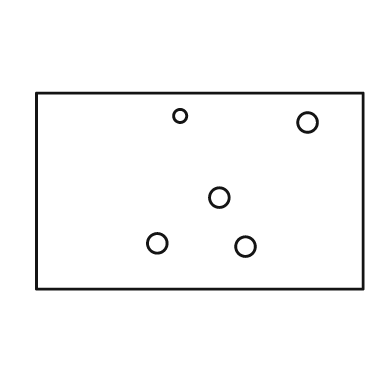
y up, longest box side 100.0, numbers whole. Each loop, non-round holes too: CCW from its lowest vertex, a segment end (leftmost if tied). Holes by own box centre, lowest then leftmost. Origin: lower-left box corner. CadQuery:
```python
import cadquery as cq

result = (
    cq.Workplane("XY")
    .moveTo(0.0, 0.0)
    .lineTo(100.0, 0.0)
    .lineTo(100.0, 60.0)
    .lineTo(0.0, 60.0)
    .close()
    .moveTo(64.0, 13.0)
    .circle(3.0)
    .moveTo(37.0, 14.0)
    .circle(3.0)
    .moveTo(56.0, 28.0)
    .circle(3.0)
    .moveTo(83.0, 51.0)
    .circle(3.0)
    .moveTo(44.0, 53.0)
    .circle(2.0)
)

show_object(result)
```